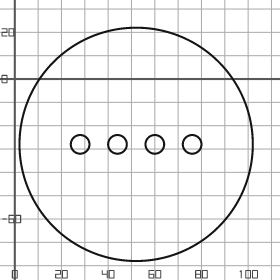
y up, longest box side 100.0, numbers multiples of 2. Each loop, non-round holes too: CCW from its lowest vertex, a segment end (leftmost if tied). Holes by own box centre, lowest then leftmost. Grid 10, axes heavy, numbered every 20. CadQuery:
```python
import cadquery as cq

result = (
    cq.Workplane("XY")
    .moveTo(52.0, -28.0)
    .circle(50.0)
    .moveTo(28.0, -28.0)
    .circle(4.0)
    .moveTo(44.0, -28.0)
    .circle(4.0)
    .moveTo(60.0, -28.0)
    .circle(4.0)
    .moveTo(76.0, -28.0)
    .circle(4.0)
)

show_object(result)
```